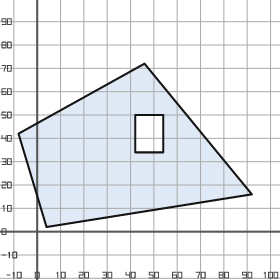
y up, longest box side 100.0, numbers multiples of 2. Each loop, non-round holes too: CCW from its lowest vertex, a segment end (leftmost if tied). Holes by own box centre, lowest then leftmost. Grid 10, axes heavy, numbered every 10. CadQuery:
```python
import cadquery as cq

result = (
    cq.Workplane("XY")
    .moveTo(4.0, 2.0)
    .lineTo(92.0, 16.0)
    .lineTo(46.0, 72.0)
    .lineTo(-8.0, 42.0)
    .close()
    .moveTo(42.0, 34.0)
    .lineTo(54.0, 34.0)
    .lineTo(54.0, 50.0)
    .lineTo(42.0, 50.0)
    .close()
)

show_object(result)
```